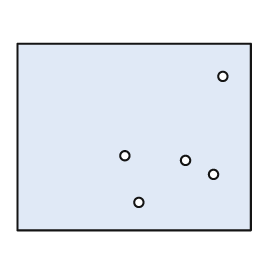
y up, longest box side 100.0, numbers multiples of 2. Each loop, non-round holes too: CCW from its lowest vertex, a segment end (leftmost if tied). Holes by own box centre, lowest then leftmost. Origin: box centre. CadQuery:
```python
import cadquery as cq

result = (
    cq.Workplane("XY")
    .moveTo(-50.0, -40.0)
    .lineTo(50.0, -40.0)
    .lineTo(50.0, 40.0)
    .lineTo(-50.0, 40.0)
    .close()
    .moveTo(2.0, -28.0)
    .circle(2.0)
    .moveTo(34.0, -16.0)
    .circle(2.0)
    .moveTo(22.0, -10.0)
    .circle(2.0)
    .moveTo(-4.0, -8.0)
    .circle(2.0)
    .moveTo(38.0, 26.0)
    .circle(2.0)
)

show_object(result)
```